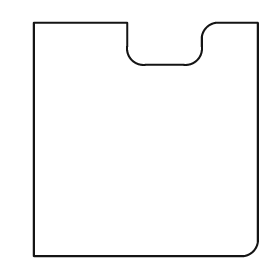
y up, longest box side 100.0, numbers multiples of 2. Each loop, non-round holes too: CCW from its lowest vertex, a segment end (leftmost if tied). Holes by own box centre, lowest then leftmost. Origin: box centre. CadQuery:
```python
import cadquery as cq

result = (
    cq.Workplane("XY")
    .moveTo(-48.0, -50.0)
    .lineTo(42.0, -50.0)
    .threePointArc((46.0, -48.0), (48.0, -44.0))
    .lineTo(48.0, 50.0)
    .lineTo(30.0, 50.0)
    .threePointArc((26.0, 48.0), (24.0, 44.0))
    .lineTo(24.0, 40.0)
    .threePointArc((22.0, 34.0), (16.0, 32.0))
    .lineTo(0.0, 32.0)
    .threePointArc((-6.0, 34.0), (-8.0, 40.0))
    .lineTo(-8.0, 50.0)
    .lineTo(-48.0, 50.0)
    .close()
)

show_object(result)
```